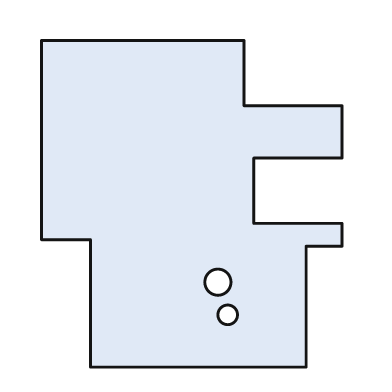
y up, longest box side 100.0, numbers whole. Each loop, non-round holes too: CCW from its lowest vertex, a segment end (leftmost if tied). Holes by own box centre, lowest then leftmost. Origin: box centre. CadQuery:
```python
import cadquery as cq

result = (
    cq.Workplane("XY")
    .moveTo(-31.0, -50.0)
    .lineTo(35.0, -50.0)
    .lineTo(35.0, -13.0)
    .lineTo(46.0, -13.0)
    .lineTo(46.0, -6.0)
    .lineTo(19.0, -6.0)
    .lineTo(19.0, 14.0)
    .lineTo(46.0, 14.0)
    .lineTo(46.0, 30.0)
    .lineTo(16.0, 30.0)
    .lineTo(16.0, 50.0)
    .lineTo(-46.0, 50.0)
    .lineTo(-46.0, -11.0)
    .lineTo(-31.0, -11.0)
    .close()
    .moveTo(11.0, -34.0)
    .circle(3.0)
    .moveTo(8.0, -24.0)
    .circle(4.0)
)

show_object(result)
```